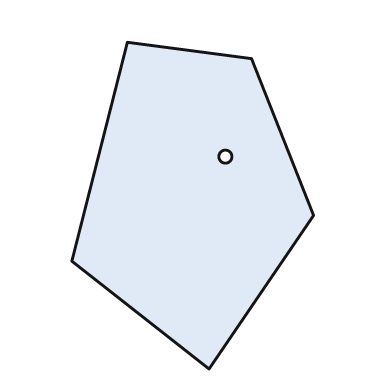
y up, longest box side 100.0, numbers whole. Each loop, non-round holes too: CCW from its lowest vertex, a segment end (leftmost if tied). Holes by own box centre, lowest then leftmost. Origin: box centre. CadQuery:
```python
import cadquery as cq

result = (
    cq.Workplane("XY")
    .moveTo(5.0, -50.0)
    .lineTo(37.0, -3.0)
    .lineTo(18.0, 45.0)
    .lineTo(-20.0, 50.0)
    .lineTo(-37.0, -17.0)
    .close()
    .moveTo(10.0, 15.0)
    .circle(2.0)
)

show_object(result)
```